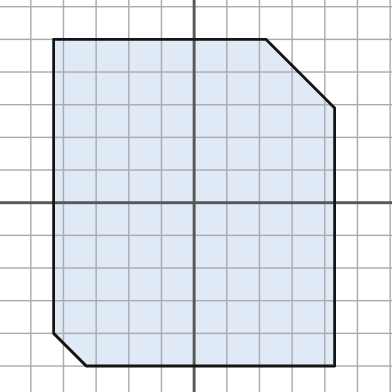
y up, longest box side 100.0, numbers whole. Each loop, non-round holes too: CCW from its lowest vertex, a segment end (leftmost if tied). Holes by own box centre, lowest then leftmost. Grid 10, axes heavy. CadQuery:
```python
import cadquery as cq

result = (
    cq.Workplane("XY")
    .moveTo(-33.0, -50.0)
    .lineTo(43.0, -50.0)
    .lineTo(43.0, 29.0)
    .lineTo(22.0, 50.0)
    .lineTo(-43.0, 50.0)
    .lineTo(-43.0, -40.0)
    .close()
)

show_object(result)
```